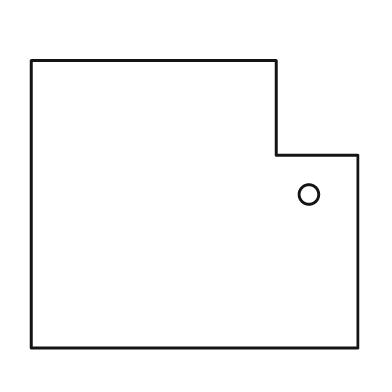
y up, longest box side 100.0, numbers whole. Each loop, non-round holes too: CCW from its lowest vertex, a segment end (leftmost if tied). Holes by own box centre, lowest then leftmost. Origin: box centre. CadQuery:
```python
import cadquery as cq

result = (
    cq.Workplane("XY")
    .moveTo(-50.0, -44.0)
    .lineTo(50.0, -44.0)
    .lineTo(50.0, 15.0)
    .lineTo(25.0, 15.0)
    .lineTo(25.0, 44.0)
    .lineTo(-50.0, 44.0)
    .close()
    .moveTo(35.0, 3.0)
    .circle(3.0)
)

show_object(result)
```